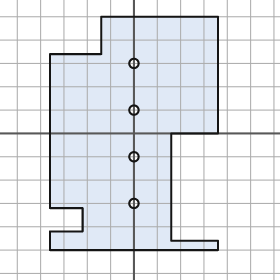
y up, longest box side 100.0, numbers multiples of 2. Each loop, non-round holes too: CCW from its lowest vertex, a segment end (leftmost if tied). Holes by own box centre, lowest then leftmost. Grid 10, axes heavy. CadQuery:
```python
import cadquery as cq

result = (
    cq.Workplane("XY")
    .moveTo(-36.0, -50.0)
    .lineTo(36.0, -50.0)
    .lineTo(36.0, -46.0)
    .lineTo(16.0, -46.0)
    .lineTo(16.0, 0.0)
    .lineTo(36.0, 0.0)
    .lineTo(36.0, 50.0)
    .lineTo(-14.0, 50.0)
    .lineTo(-14.0, 34.0)
    .lineTo(-36.0, 34.0)
    .lineTo(-36.0, -32.0)
    .lineTo(-22.0, -32.0)
    .lineTo(-22.0, -42.0)
    .lineTo(-36.0, -42.0)
    .close()
    .moveTo(0.0, -30.0)
    .circle(2.0)
    .moveTo(0.0, -10.0)
    .circle(2.0)
    .moveTo(0.0, 10.0)
    .circle(2.0)
    .moveTo(0.0, 30.0)
    .circle(2.0)
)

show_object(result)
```